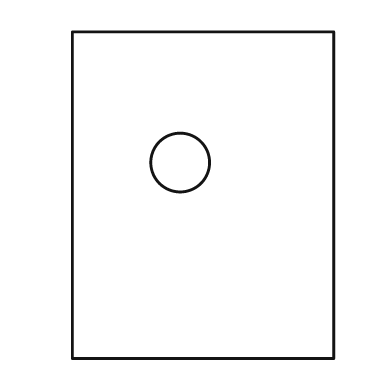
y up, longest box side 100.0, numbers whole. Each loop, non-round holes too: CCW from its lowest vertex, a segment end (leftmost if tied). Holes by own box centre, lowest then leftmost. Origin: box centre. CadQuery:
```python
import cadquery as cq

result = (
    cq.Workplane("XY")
    .moveTo(-40.0, -50.0)
    .lineTo(40.0, -50.0)
    .lineTo(40.0, 50.0)
    .lineTo(-40.0, 50.0)
    .close()
    .moveTo(-7.0, 10.0)
    .circle(9.0)
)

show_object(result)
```